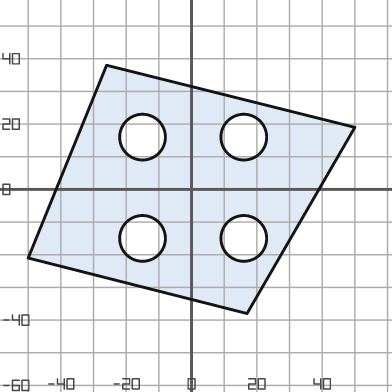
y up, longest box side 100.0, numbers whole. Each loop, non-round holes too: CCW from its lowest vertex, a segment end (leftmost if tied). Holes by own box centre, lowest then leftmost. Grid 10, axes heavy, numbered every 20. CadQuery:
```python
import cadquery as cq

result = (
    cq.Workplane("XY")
    .moveTo(17.0, -38.0)
    .lineTo(50.0, 19.0)
    .lineTo(-26.0, 38.0)
    .lineTo(-50.0, -21.0)
    .close()
    .moveTo(-15.0, -15.0)
    .circle(7.0)
    .moveTo(16.0, -15.0)
    .circle(7.0)
    .moveTo(-15.0, 16.0)
    .circle(7.0)
    .moveTo(16.0, 16.0)
    .circle(7.0)
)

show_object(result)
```